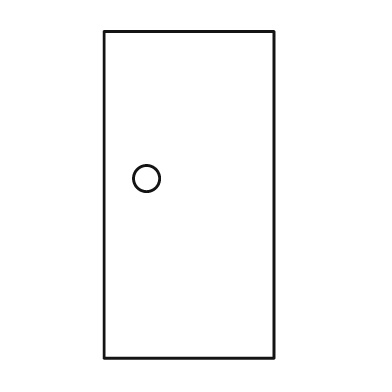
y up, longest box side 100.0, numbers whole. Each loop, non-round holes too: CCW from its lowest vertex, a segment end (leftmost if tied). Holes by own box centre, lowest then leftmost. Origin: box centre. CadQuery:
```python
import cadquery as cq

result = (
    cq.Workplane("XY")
    .moveTo(-26.0, -50.0)
    .lineTo(26.0, -50.0)
    .lineTo(26.0, 50.0)
    .lineTo(-26.0, 50.0)
    .close()
    .moveTo(-13.0, 5.0)
    .circle(4.0)
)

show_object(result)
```